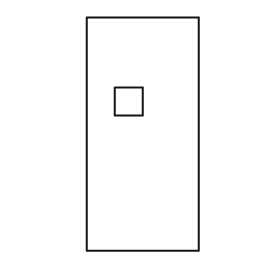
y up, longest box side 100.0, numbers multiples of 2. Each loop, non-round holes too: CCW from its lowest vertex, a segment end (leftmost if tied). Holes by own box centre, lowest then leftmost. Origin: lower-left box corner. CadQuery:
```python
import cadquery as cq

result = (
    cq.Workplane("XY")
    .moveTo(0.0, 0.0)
    .lineTo(48.0, 0.0)
    .lineTo(48.0, 100.0)
    .lineTo(0.0, 100.0)
    .close()
    .moveTo(12.0, 58.0)
    .lineTo(24.0, 58.0)
    .lineTo(24.0, 70.0)
    .lineTo(12.0, 70.0)
    .close()
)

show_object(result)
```